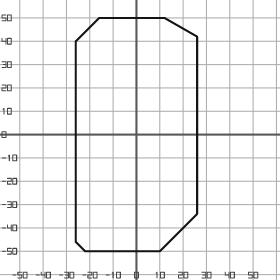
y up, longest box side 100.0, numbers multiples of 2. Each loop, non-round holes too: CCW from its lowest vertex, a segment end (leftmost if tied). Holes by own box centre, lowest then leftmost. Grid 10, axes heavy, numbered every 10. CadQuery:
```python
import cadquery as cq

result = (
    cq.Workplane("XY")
    .moveTo(-22.0, -50.0)
    .lineTo(10.0, -50.0)
    .lineTo(26.0, -34.0)
    .lineTo(26.0, 42.0)
    .lineTo(12.0, 50.0)
    .lineTo(-16.0, 50.0)
    .lineTo(-26.0, 40.0)
    .lineTo(-26.0, -46.0)
    .close()
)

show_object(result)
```